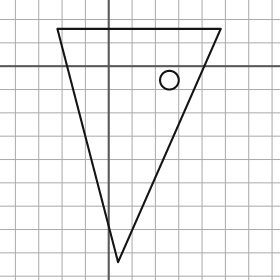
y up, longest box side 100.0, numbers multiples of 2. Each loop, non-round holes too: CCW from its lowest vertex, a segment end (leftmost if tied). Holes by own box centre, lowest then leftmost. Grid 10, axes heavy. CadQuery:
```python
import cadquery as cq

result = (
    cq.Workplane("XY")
    .moveTo(4.0, -84.0)
    .lineTo(48.0, 16.0)
    .lineTo(-22.0, 16.0)
    .close()
    .moveTo(26.0, -6.0)
    .circle(4.0)
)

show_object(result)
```